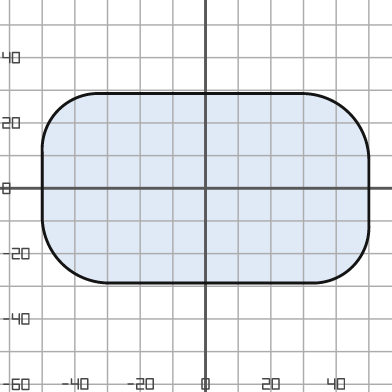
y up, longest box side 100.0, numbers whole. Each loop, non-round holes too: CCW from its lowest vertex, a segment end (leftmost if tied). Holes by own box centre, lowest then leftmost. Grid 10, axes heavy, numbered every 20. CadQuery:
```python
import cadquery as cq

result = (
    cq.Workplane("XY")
    .moveTo(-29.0, -29.0)
    .lineTo(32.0, -29.0)
    .threePointArc((45.0, -24.0), (50.0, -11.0))
    .lineTo(50.0, 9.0)
    .threePointArc((44.0, 23.0), (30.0, 29.0))
    .lineTo(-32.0, 29.0)
    .threePointArc((-45.0, 24.0), (-50.0, 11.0))
    .lineTo(-50.0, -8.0)
    .threePointArc((-44.0, -23.0), (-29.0, -29.0))
    .close()
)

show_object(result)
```